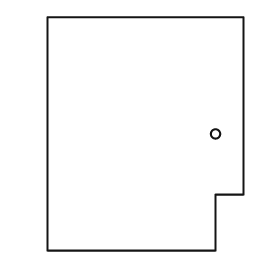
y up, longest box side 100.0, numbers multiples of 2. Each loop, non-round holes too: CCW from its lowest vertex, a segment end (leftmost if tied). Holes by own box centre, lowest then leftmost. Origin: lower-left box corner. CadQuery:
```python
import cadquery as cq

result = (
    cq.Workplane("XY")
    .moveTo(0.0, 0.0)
    .lineTo(72.0, 0.0)
    .lineTo(72.0, 24.0)
    .lineTo(84.0, 24.0)
    .lineTo(84.0, 100.0)
    .lineTo(0.0, 100.0)
    .close()
    .moveTo(72.0, 50.0)
    .circle(2.0)
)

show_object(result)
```